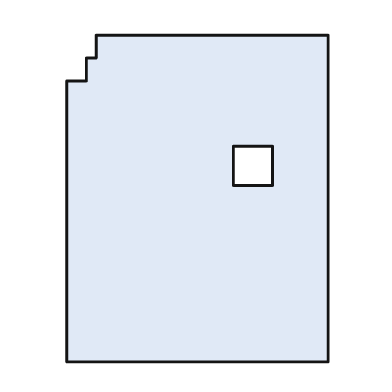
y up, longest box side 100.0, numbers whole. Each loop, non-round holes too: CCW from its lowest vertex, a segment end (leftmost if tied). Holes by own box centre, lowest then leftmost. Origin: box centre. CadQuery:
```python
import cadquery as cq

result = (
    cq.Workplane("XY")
    .moveTo(-40.0, -50.0)
    .lineTo(40.0, -50.0)
    .lineTo(40.0, 50.0)
    .lineTo(-31.0, 50.0)
    .lineTo(-31.0, 43.0)
    .lineTo(-34.0, 43.0)
    .lineTo(-34.0, 36.0)
    .lineTo(-40.0, 36.0)
    .close()
    .moveTo(11.0, 4.0)
    .lineTo(23.0, 4.0)
    .lineTo(23.0, 16.0)
    .lineTo(11.0, 16.0)
    .close()
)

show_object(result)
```